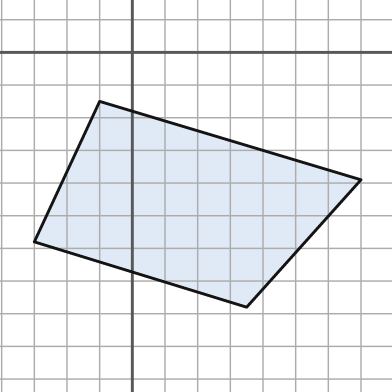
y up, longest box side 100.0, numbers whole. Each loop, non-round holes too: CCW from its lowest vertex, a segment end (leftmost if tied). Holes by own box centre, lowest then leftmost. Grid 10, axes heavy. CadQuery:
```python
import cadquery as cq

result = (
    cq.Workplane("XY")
    .moveTo(35.0, -78.0)
    .lineTo(70.0, -39.0)
    .lineTo(-10.0, -15.0)
    .lineTo(-30.0, -58.0)
    .close()
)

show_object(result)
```